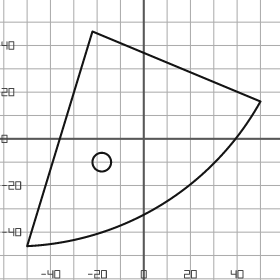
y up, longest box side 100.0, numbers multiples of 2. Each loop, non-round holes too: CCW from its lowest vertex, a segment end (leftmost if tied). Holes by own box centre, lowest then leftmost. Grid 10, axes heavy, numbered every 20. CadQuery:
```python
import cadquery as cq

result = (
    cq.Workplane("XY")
    .moveTo(-50.0, -46.0)
    .threePointArc((8.0, -28.0), (50.0, 16.0))
    .lineTo(-22.0, 46.0)
    .close()
    .moveTo(-18.0, -10.0)
    .circle(4.0)
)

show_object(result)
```